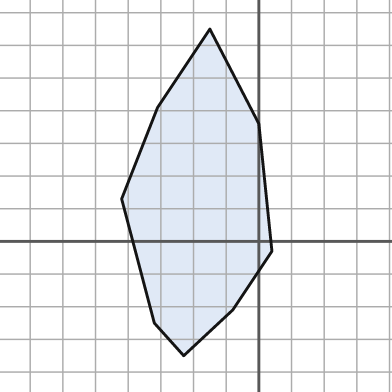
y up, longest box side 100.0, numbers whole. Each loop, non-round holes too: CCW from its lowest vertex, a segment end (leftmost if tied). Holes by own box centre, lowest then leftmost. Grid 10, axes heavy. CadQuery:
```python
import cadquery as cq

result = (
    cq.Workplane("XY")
    .moveTo(-23.0, -35.0)
    .lineTo(-8.0, -21.0)
    .lineTo(4.0, -3.0)
    .lineTo(0.0, 36.0)
    .lineTo(-15.0, 65.0)
    .lineTo(-31.0, 41.0)
    .lineTo(-42.0, 13.0)
    .lineTo(-32.0, -25.0)
    .close()
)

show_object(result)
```